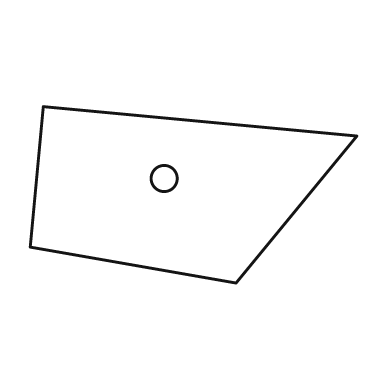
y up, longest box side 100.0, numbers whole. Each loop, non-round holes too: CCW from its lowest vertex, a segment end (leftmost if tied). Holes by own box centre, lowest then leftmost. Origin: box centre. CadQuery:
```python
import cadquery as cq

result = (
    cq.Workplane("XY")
    .moveTo(13.0, -27.0)
    .lineTo(50.0, 18.0)
    .lineTo(-46.0, 27.0)
    .lineTo(-50.0, -16.0)
    .close()
    .moveTo(-9.0, 5.0)
    .circle(4.0)
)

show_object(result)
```